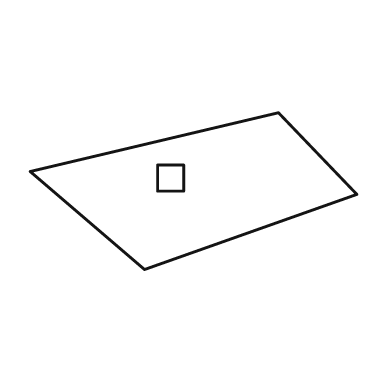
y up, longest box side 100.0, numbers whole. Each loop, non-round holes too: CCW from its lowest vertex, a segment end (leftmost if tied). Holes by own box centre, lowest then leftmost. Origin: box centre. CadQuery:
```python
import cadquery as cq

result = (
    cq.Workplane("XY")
    .moveTo(-15.0, -24.0)
    .lineTo(50.0, -1.0)
    .lineTo(26.0, 24.0)
    .lineTo(-50.0, 6.0)
    .close()
    .moveTo(-11.0, 0.0)
    .lineTo(-3.0, 0.0)
    .lineTo(-3.0, 8.0)
    .lineTo(-11.0, 8.0)
    .close()
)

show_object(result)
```